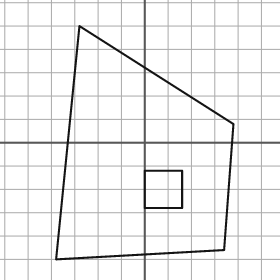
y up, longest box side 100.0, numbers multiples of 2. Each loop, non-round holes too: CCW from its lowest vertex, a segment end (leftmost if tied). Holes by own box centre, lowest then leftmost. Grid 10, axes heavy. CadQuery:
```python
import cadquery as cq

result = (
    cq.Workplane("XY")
    .moveTo(-38.0, -50.0)
    .lineTo(34.0, -46.0)
    .lineTo(38.0, 8.0)
    .lineTo(-28.0, 50.0)
    .close()
    .moveTo(0.0, -28.0)
    .lineTo(16.0, -28.0)
    .lineTo(16.0, -12.0)
    .lineTo(0.0, -12.0)
    .close()
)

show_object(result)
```